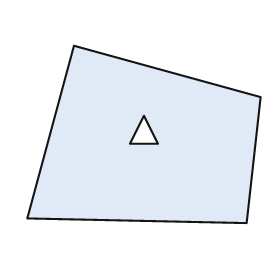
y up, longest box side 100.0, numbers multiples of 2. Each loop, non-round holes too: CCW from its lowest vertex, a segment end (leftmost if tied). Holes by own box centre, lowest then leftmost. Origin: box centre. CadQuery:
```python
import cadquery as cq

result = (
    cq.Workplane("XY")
    .moveTo(44.0, -38.0)
    .lineTo(50.0, 16.0)
    .lineTo(-30.0, 38.0)
    .lineTo(-50.0, -36.0)
    .close()
    .moveTo(-6.0, -4.0)
    .lineTo(6.0, -4.0)
    .lineTo(0.0, 8.0)
    .close()
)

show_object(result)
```